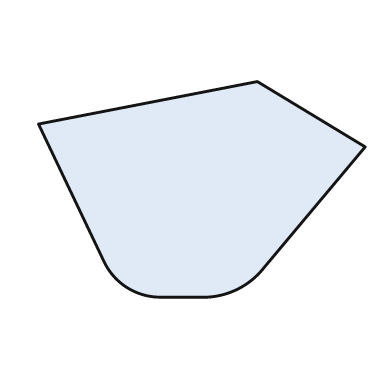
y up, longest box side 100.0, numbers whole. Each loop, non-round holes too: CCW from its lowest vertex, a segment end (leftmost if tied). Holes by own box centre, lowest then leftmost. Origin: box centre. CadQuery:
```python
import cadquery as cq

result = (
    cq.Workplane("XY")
    .moveTo(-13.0, -33.0)
    .lineTo(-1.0, -33.0)
    .threePointArc((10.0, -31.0), (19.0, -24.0))
    .lineTo(50.0, 13.0)
    .lineTo(17.0, 33.0)
    .lineTo(-50.0, 20.0)
    .lineTo(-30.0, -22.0)
    .threePointArc((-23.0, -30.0), (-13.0, -33.0))
    .close()
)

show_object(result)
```